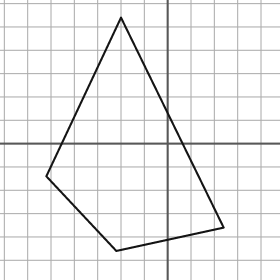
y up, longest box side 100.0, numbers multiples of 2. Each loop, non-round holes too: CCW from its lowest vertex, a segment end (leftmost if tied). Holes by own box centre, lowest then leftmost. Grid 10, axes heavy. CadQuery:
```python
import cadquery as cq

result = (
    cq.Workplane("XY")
    .moveTo(-22.0, -46.0)
    .lineTo(24.0, -36.0)
    .lineTo(-20.0, 54.0)
    .lineTo(-52.0, -14.0)
    .close()
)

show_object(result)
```